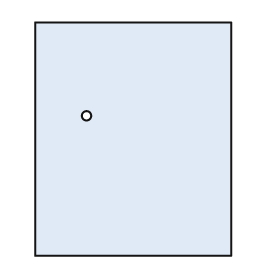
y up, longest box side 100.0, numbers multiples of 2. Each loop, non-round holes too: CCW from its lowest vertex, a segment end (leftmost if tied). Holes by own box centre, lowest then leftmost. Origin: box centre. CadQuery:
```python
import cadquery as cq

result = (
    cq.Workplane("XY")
    .moveTo(-42.0, -50.0)
    .lineTo(42.0, -50.0)
    .lineTo(42.0, 50.0)
    .lineTo(-42.0, 50.0)
    .close()
    .moveTo(-20.0, 10.0)
    .circle(2.0)
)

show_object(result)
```